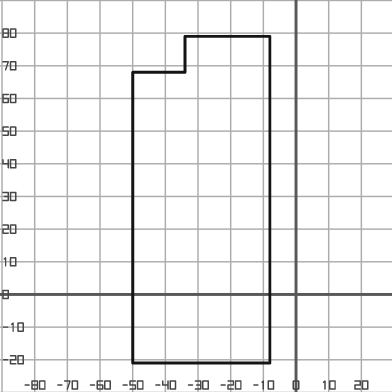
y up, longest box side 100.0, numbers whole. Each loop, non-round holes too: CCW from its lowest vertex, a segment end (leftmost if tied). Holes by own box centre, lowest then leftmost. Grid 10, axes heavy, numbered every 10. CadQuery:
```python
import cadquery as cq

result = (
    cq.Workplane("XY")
    .moveTo(-50.0, -21.0)
    .lineTo(-8.0, -21.0)
    .lineTo(-8.0, 79.0)
    .lineTo(-34.0, 79.0)
    .lineTo(-34.0, 68.0)
    .lineTo(-50.0, 68.0)
    .close()
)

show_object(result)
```